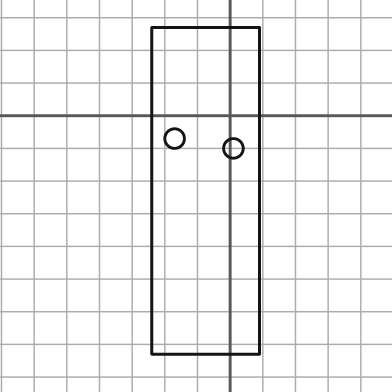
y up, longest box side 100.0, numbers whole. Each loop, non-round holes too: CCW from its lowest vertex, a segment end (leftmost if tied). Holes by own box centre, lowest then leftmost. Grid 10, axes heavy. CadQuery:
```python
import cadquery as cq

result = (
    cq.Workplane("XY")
    .moveTo(-24.0, -73.0)
    .lineTo(9.0, -73.0)
    .lineTo(9.0, 27.0)
    .lineTo(-24.0, 27.0)
    .close()
    .moveTo(1.0, -10.0)
    .circle(3.0)
    .moveTo(-17.0, -7.0)
    .circle(3.0)
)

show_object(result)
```